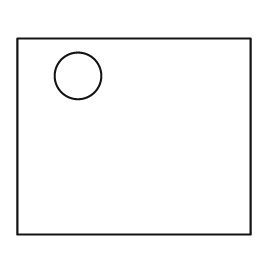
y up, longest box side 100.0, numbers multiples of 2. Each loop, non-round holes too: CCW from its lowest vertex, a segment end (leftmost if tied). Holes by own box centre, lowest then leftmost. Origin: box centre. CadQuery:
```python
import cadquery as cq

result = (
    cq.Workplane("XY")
    .moveTo(-50.0, -42.0)
    .lineTo(50.0, -42.0)
    .lineTo(50.0, 42.0)
    .lineTo(-50.0, 42.0)
    .close()
    .moveTo(-24.0, 26.0)
    .circle(10.0)
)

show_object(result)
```